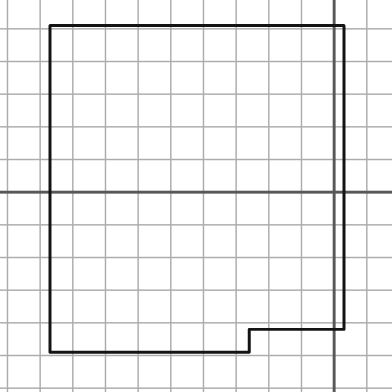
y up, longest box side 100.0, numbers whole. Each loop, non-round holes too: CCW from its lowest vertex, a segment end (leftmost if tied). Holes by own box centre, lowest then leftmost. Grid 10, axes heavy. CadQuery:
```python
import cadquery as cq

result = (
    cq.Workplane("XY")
    .moveTo(-87.0, -49.0)
    .lineTo(-26.0, -49.0)
    .lineTo(-26.0, -42.0)
    .lineTo(3.0, -42.0)
    .lineTo(3.0, 51.0)
    .lineTo(-87.0, 51.0)
    .close()
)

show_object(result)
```